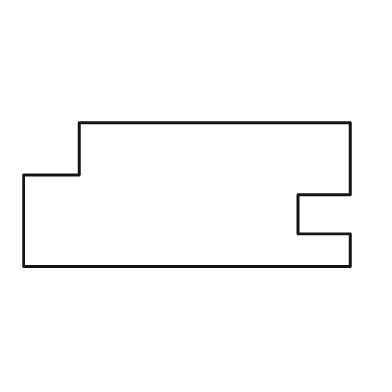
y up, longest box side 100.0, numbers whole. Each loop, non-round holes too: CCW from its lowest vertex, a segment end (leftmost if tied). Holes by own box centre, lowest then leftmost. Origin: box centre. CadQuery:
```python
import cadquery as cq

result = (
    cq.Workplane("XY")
    .moveTo(-50.0, -22.0)
    .lineTo(50.0, -22.0)
    .lineTo(50.0, -12.0)
    .lineTo(34.0, -12.0)
    .lineTo(34.0, 0.0)
    .lineTo(50.0, 0.0)
    .lineTo(50.0, 22.0)
    .lineTo(-33.0, 22.0)
    .lineTo(-33.0, 6.0)
    .lineTo(-50.0, 6.0)
    .close()
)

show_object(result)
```